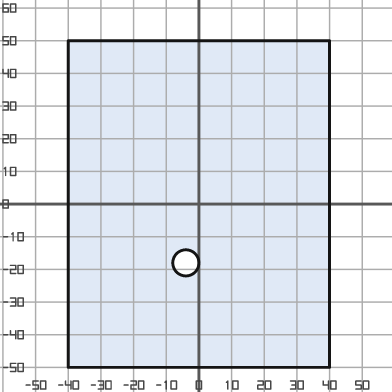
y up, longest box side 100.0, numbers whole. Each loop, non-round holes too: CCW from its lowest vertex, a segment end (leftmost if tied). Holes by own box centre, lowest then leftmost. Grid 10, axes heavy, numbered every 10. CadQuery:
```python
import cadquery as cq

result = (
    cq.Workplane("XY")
    .moveTo(-40.0, -50.0)
    .lineTo(40.0, -50.0)
    .lineTo(40.0, 50.0)
    .lineTo(-40.0, 50.0)
    .close()
    .moveTo(-4.0, -18.0)
    .circle(4.0)
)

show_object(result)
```